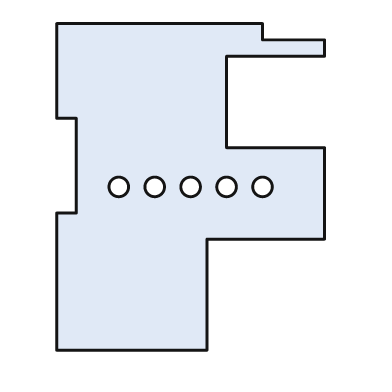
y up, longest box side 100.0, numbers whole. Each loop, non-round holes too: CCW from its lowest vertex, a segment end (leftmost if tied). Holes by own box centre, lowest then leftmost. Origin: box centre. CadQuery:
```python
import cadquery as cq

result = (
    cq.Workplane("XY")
    .moveTo(-41.0, -50.0)
    .lineTo(5.0, -50.0)
    .lineTo(5.0, -16.0)
    .lineTo(41.0, -16.0)
    .lineTo(41.0, 12.0)
    .lineTo(11.0, 12.0)
    .lineTo(11.0, 40.0)
    .lineTo(41.0, 40.0)
    .lineTo(41.0, 45.0)
    .lineTo(22.0, 45.0)
    .lineTo(22.0, 50.0)
    .lineTo(-41.0, 50.0)
    .lineTo(-41.0, 21.0)
    .lineTo(-35.0, 21.0)
    .lineTo(-35.0, -8.0)
    .lineTo(-41.0, -8.0)
    .close()
    .moveTo(-22.0, 0.0)
    .circle(3.0)
    .moveTo(-11.0, 0.0)
    .circle(3.0)
    .moveTo(0.0, 0.0)
    .circle(3.0)
    .moveTo(11.0, 0.0)
    .circle(3.0)
    .moveTo(22.0, 0.0)
    .circle(3.0)
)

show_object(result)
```